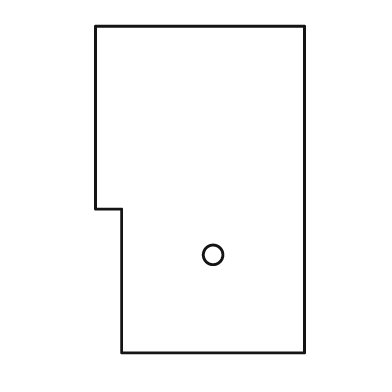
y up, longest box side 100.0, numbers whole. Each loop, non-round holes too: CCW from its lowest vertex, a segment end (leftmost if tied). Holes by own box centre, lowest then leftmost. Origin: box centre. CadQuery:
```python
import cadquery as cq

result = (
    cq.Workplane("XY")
    .moveTo(-24.0, -50.0)
    .lineTo(32.0, -50.0)
    .lineTo(32.0, 50.0)
    .lineTo(-32.0, 50.0)
    .lineTo(-32.0, -6.0)
    .lineTo(-24.0, -6.0)
    .close()
    .moveTo(4.0, -20.0)
    .circle(3.0)
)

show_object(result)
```